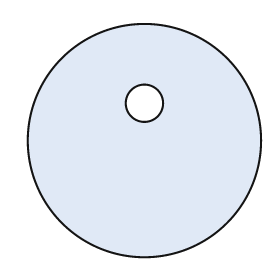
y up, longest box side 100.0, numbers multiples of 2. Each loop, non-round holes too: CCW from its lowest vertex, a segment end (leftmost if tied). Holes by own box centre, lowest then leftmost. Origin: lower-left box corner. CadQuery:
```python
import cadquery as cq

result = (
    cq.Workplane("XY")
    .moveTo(50.0, 50.0)
    .circle(50.0)
    .moveTo(50.0, 66.0)
    .circle(8.0)
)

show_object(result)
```